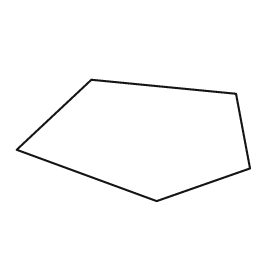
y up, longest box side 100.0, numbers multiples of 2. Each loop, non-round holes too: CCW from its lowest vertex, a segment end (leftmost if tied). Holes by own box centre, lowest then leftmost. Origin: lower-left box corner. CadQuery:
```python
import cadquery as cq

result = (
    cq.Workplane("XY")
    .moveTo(60.0, 0.0)
    .lineTo(100.0, 14.0)
    .lineTo(94.0, 46.0)
    .lineTo(32.0, 52.0)
    .lineTo(0.0, 22.0)
    .close()
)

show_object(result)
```